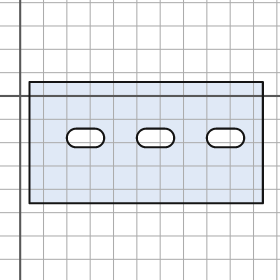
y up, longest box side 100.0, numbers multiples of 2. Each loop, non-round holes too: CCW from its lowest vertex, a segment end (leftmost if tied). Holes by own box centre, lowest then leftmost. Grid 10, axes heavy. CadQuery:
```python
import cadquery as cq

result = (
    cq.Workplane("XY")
    .moveTo(4.0, -46.0)
    .lineTo(104.0, -46.0)
    .lineTo(104.0, 6.0)
    .lineTo(4.0, 6.0)
    .close()
    .moveTo(24.0, -22.0)
    .lineTo(32.0, -22.0)
    .threePointArc((36.0, -18.0), (32.0, -14.0))
    .lineTo(24.0, -14.0)
    .threePointArc((20.0, -18.0), (24.0, -22.0))
    .close()
    .moveTo(54.0, -22.0)
    .lineTo(62.0, -22.0)
    .threePointArc((66.0, -18.0), (62.0, -14.0))
    .lineTo(54.0, -14.0)
    .threePointArc((50.0, -18.0), (54.0, -22.0))
    .close()
    .moveTo(84.0, -22.0)
    .lineTo(92.0, -22.0)
    .threePointArc((96.0, -18.0), (92.0, -14.0))
    .lineTo(84.0, -14.0)
    .threePointArc((80.0, -18.0), (84.0, -22.0))
    .close()
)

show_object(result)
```